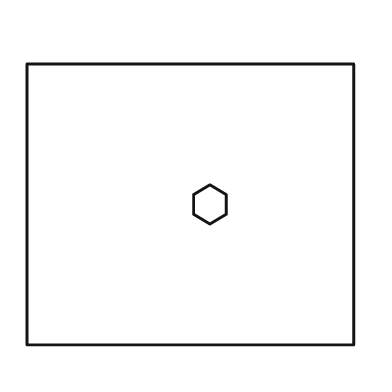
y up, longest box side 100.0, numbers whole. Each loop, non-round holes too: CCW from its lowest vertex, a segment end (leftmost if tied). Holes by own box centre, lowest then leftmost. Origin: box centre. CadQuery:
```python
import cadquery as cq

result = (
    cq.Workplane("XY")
    .moveTo(-50.0, -43.0)
    .lineTo(50.0, -43.0)
    .lineTo(50.0, 43.0)
    .lineTo(-50.0, 43.0)
    .close()
    .moveTo(6.0, -6.0)
    .lineTo(11.0, -3.0)
    .lineTo(11.0, 3.0)
    .lineTo(6.0, 6.0)
    .lineTo(1.0, 3.0)
    .lineTo(1.0, -3.0)
    .close()
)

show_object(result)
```